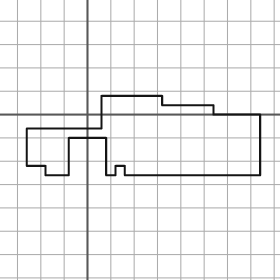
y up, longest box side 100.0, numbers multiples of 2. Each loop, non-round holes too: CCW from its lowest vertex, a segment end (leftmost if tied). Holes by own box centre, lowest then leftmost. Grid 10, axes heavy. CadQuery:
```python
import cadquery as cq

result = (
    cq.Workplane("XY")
    .moveTo(-18.0, -26.0)
    .lineTo(-8.0, -26.0)
    .lineTo(-8.0, -10.0)
    .lineTo(8.0, -10.0)
    .lineTo(8.0, -26.0)
    .lineTo(12.0, -26.0)
    .lineTo(12.0, -22.0)
    .lineTo(16.0, -22.0)
    .lineTo(16.0, -26.0)
    .lineTo(74.0, -26.0)
    .lineTo(74.0, 0.0)
    .lineTo(54.0, 0.0)
    .lineTo(54.0, 4.0)
    .lineTo(32.0, 4.0)
    .lineTo(32.0, 8.0)
    .lineTo(6.0, 8.0)
    .lineTo(6.0, -6.0)
    .lineTo(-26.0, -6.0)
    .lineTo(-26.0, -22.0)
    .lineTo(-18.0, -22.0)
    .close()
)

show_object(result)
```